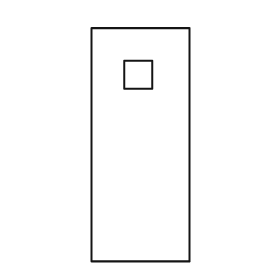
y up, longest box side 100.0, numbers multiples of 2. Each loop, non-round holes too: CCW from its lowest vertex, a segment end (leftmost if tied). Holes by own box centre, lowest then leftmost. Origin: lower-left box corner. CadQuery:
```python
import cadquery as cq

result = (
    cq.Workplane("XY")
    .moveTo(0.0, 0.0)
    .lineTo(42.0, 0.0)
    .lineTo(42.0, 100.0)
    .lineTo(0.0, 100.0)
    .close()
    .moveTo(14.0, 74.0)
    .lineTo(26.0, 74.0)
    .lineTo(26.0, 86.0)
    .lineTo(14.0, 86.0)
    .close()
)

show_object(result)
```